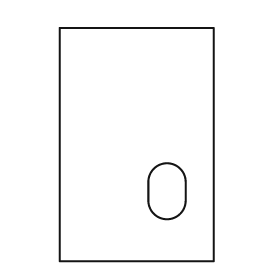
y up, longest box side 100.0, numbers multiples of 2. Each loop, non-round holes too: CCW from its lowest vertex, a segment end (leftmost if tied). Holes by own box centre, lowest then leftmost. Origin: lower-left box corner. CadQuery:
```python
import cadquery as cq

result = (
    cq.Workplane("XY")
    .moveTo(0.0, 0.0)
    .lineTo(66.0, 0.0)
    .lineTo(66.0, 100.0)
    .lineTo(0.0, 100.0)
    .close()
    .moveTo(38.0, 26.0)
    .threePointArc((46.0, 18.0), (54.0, 26.0))
    .lineTo(54.0, 34.0)
    .threePointArc((46.0, 42.0), (38.0, 34.0))
    .close()
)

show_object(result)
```